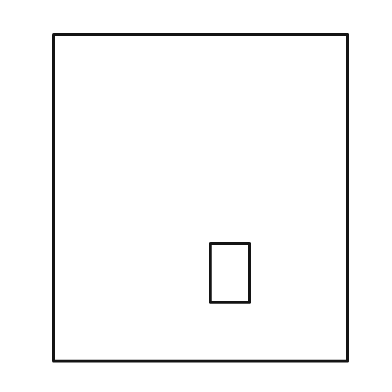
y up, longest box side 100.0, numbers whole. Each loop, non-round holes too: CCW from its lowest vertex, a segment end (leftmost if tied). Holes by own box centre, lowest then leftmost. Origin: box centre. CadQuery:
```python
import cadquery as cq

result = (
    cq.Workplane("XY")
    .moveTo(-45.0, -50.0)
    .lineTo(45.0, -50.0)
    .lineTo(45.0, 50.0)
    .lineTo(-45.0, 50.0)
    .close()
    .moveTo(3.0, -32.0)
    .lineTo(15.0, -32.0)
    .lineTo(15.0, -14.0)
    .lineTo(3.0, -14.0)
    .close()
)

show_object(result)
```